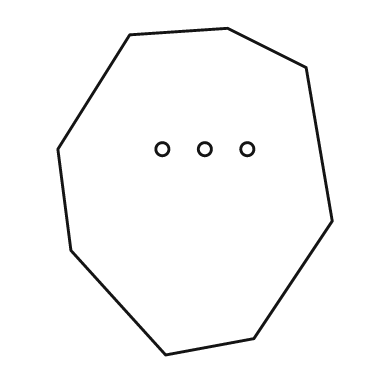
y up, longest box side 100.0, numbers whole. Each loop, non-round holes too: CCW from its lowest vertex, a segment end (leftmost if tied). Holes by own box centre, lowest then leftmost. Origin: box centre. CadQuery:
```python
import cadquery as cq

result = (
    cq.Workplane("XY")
    .moveTo(-9.0, -50.0)
    .lineTo(18.0, -45.0)
    .lineTo(42.0, -9.0)
    .lineTo(34.0, 38.0)
    .lineTo(10.0, 50.0)
    .lineTo(-20.0, 48.0)
    .lineTo(-42.0, 13.0)
    .lineTo(-38.0, -18.0)
    .close()
    .moveTo(-10.0, 13.0)
    .circle(2.0)
    .moveTo(3.0, 13.0)
    .circle(2.0)
    .moveTo(16.0, 13.0)
    .circle(2.0)
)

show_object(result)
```